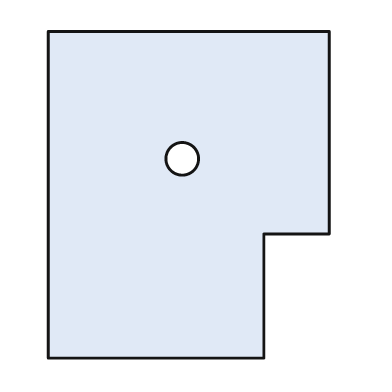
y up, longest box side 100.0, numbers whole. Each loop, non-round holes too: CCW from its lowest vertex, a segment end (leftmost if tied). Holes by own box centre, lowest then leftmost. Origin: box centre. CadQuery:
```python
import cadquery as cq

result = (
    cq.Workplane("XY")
    .moveTo(-43.0, -50.0)
    .lineTo(23.0, -50.0)
    .lineTo(23.0, -12.0)
    .lineTo(43.0, -12.0)
    .lineTo(43.0, 50.0)
    .lineTo(-43.0, 50.0)
    .close()
    .moveTo(-2.0, 11.0)
    .circle(5.0)
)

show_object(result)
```